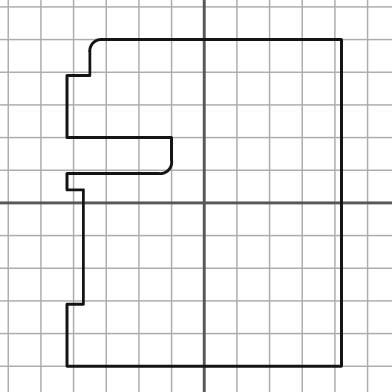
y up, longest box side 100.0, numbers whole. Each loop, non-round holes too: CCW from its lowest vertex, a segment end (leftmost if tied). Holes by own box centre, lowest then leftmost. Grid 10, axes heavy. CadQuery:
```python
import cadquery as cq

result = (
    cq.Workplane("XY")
    .moveTo(-42.0, -50.0)
    .lineTo(42.0, -50.0)
    .lineTo(42.0, 50.0)
    .lineTo(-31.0, 50.0)
    .threePointArc((-34.0, 49.0), (-35.0, 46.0))
    .lineTo(-35.0, 39.0)
    .lineTo(-42.0, 39.0)
    .lineTo(-42.0, 20.0)
    .lineTo(-10.0, 20.0)
    .lineTo(-10.0, 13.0)
    .threePointArc((-11.0, 10.0), (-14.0, 9.0))
    .lineTo(-42.0, 9.0)
    .lineTo(-42.0, 4.0)
    .lineTo(-37.0, 4.0)
    .lineTo(-37.0, -31.0)
    .lineTo(-42.0, -31.0)
    .close()
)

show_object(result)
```